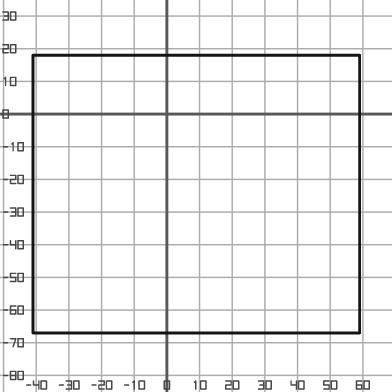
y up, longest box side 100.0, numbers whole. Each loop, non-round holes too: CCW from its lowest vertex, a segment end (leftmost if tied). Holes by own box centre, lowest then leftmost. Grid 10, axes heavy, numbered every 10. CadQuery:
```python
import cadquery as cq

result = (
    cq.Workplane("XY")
    .moveTo(-41.0, -67.0)
    .lineTo(59.0, -67.0)
    .lineTo(59.0, 18.0)
    .lineTo(-41.0, 18.0)
    .close()
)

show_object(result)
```